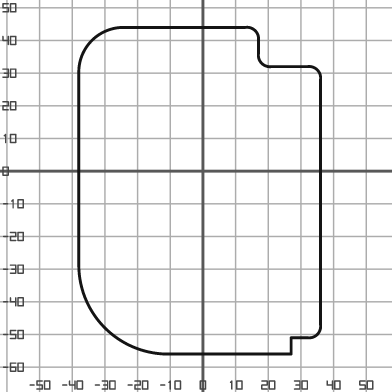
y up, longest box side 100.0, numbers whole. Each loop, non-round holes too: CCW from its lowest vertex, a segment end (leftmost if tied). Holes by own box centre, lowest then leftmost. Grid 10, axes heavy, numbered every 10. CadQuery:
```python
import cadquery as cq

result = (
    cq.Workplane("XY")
    .moveTo(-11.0, -56.0)
    .lineTo(27.0, -56.0)
    .lineTo(27.0, -51.0)
    .lineTo(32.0, -51.0)
    .threePointArc((35.0, -50.0), (36.0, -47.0))
    .lineTo(36.0, 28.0)
    .threePointArc((35.0, 31.0), (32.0, 32.0))
    .lineTo(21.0, 32.0)
    .threePointArc((18.0, 33.0), (17.0, 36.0))
    .lineTo(17.0, 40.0)
    .threePointArc((16.0, 43.0), (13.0, 44.0))
    .lineTo(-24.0, 44.0)
    .threePointArc((-34.0, 40.0), (-38.0, 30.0))
    .lineTo(-38.0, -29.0)
    .threePointArc((-30.0, -48.0), (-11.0, -56.0))
    .close()
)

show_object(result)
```